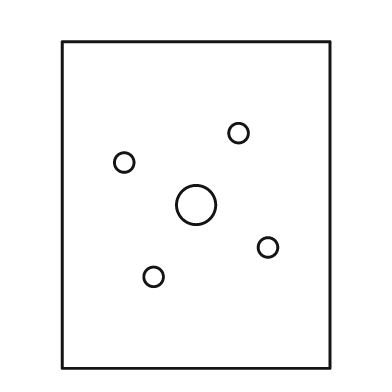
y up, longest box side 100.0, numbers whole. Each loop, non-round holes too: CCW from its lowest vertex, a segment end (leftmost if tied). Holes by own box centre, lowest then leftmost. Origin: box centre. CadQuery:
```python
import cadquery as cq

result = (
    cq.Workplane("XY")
    .moveTo(-41.0, -50.0)
    .lineTo(41.0, -50.0)
    .lineTo(41.0, 50.0)
    .lineTo(-41.0, 50.0)
    .close()
    .moveTo(-13.0, -22.0)
    .circle(3.0)
    .moveTo(22.0, -13.0)
    .circle(3.0)
    .moveTo(0.0, 0.0)
    .circle(6.0)
    .moveTo(-22.0, 13.0)
    .circle(3.0)
    .moveTo(13.0, 22.0)
    .circle(3.0)
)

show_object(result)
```